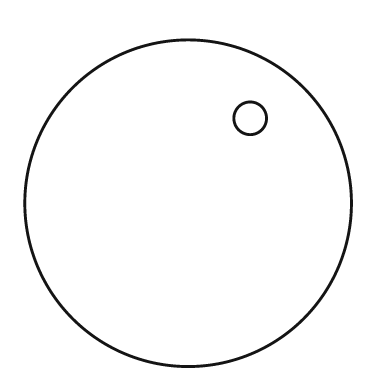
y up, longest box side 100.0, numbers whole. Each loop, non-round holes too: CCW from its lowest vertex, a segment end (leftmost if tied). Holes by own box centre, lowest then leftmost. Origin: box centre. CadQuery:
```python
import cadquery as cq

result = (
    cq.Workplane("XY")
    .moveTo(0.0, 0.0)
    .circle(50.0)
    .moveTo(19.0, 26.0)
    .circle(5.0)
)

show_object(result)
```